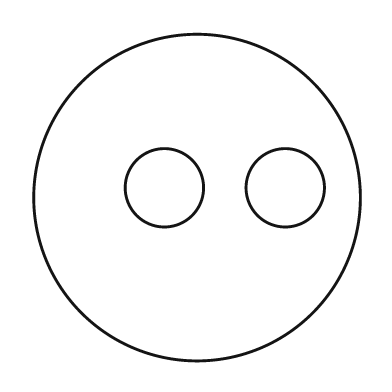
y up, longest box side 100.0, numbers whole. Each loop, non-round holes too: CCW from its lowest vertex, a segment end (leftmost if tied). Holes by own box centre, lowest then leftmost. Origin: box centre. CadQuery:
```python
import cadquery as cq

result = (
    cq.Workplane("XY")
    .moveTo(0.0, 0.0)
    .circle(50.0)
    .moveTo(-10.0, 3.0)
    .circle(12.0)
    .moveTo(27.0, 3.0)
    .circle(12.0)
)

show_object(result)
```